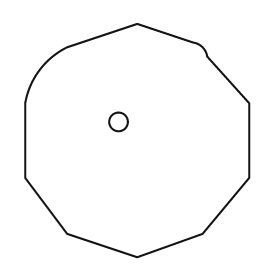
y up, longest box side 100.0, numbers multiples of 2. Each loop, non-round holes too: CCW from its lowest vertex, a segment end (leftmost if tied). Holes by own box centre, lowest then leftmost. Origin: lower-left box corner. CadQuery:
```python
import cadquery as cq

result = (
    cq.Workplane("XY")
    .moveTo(48.0, 0.0)
    .lineTo(76.0, 10.0)
    .lineTo(96.0, 34.0)
    .lineTo(96.0, 66.0)
    .lineTo(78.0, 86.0)
    .threePointArc((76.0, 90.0), (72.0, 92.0))
    .lineTo(48.0, 100.0)
    .lineTo(18.0, 90.0)
    .threePointArc((6.0, 80.0), (0.0, 66.0))
    .lineTo(0.0, 34.0)
    .lineTo(18.0, 10.0)
    .close()
    .moveTo(40.0, 58.0)
    .circle(4.0)
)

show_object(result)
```